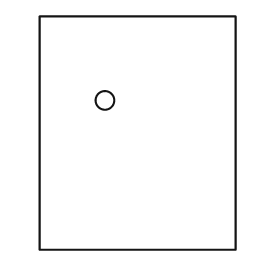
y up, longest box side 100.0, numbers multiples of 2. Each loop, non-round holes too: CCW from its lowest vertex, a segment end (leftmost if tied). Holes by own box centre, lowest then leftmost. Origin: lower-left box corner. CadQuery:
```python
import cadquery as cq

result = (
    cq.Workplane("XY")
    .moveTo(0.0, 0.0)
    .lineTo(84.0, 0.0)
    .lineTo(84.0, 100.0)
    .lineTo(0.0, 100.0)
    .close()
    .moveTo(28.0, 64.0)
    .circle(4.0)
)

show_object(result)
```